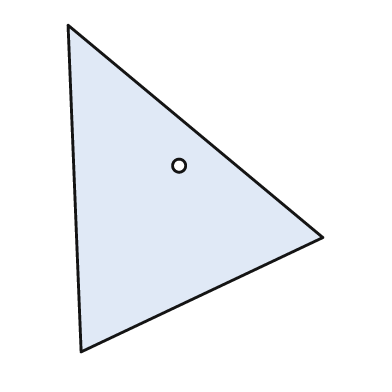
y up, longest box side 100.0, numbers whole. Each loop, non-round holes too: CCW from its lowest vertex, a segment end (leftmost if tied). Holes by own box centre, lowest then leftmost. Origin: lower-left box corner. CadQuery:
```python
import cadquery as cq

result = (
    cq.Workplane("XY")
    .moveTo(4.0, 0.0)
    .lineTo(78.0, 35.0)
    .lineTo(0.0, 100.0)
    .close()
    .moveTo(34.0, 57.0)
    .circle(2.0)
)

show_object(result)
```